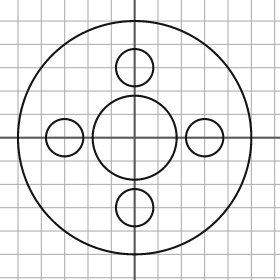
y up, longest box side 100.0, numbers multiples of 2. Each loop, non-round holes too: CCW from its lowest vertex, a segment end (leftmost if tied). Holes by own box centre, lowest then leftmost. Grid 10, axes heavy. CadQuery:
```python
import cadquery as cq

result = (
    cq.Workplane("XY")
    .moveTo(0.0, 0.0)
    .circle(50.0)
    .moveTo(0.0, -30.0)
    .circle(8.0)
    .moveTo(-30.0, 0.0)
    .circle(8.0)
    .moveTo(0.0, 0.0)
    .circle(18.0)
    .moveTo(30.0, 0.0)
    .circle(8.0)
    .moveTo(0.0, 30.0)
    .circle(8.0)
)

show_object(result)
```